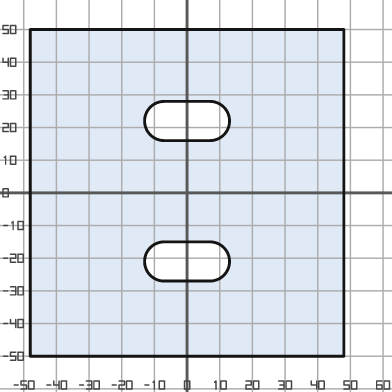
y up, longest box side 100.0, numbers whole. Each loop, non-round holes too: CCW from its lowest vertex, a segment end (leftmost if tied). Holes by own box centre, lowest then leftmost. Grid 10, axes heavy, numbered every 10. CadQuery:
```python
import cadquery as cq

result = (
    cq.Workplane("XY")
    .moveTo(-48.0, -50.0)
    .lineTo(48.0, -50.0)
    .lineTo(48.0, 50.0)
    .lineTo(-48.0, 50.0)
    .close()
    .moveTo(-7.0, -27.0)
    .lineTo(7.0, -27.0)
    .threePointArc((13.0, -21.0), (7.0, -15.0))
    .lineTo(-7.0, -15.0)
    .threePointArc((-13.0, -21.0), (-7.0, -27.0))
    .close()
    .moveTo(-7.0, 16.0)
    .lineTo(7.0, 16.0)
    .threePointArc((13.0, 22.0), (7.0, 28.0))
    .lineTo(-7.0, 28.0)
    .threePointArc((-13.0, 22.0), (-7.0, 16.0))
    .close()
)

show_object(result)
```